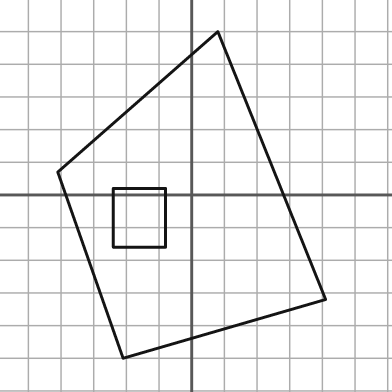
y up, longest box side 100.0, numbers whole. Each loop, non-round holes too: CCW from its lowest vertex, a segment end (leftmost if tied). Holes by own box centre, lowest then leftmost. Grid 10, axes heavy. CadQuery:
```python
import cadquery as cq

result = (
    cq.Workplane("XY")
    .moveTo(-21.0, -50.0)
    .lineTo(41.0, -32.0)
    .lineTo(8.0, 50.0)
    .lineTo(-41.0, 7.0)
    .close()
    .moveTo(-24.0, -16.0)
    .lineTo(-8.0, -16.0)
    .lineTo(-8.0, 2.0)
    .lineTo(-24.0, 2.0)
    .close()
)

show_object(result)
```